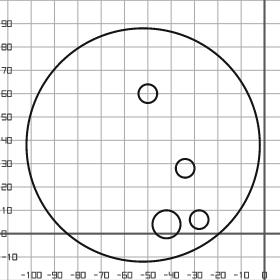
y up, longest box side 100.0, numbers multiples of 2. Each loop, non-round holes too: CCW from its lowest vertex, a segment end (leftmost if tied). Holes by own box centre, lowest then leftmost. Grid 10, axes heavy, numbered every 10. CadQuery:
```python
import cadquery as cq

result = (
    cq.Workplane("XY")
    .moveTo(-52.0, 38.0)
    .circle(50.0)
    .moveTo(-42.0, 4.0)
    .circle(6.0)
    .moveTo(-28.0, 6.0)
    .circle(4.0)
    .moveTo(-34.0, 28.0)
    .circle(4.0)
    .moveTo(-50.0, 60.0)
    .circle(4.0)
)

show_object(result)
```